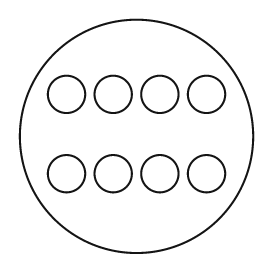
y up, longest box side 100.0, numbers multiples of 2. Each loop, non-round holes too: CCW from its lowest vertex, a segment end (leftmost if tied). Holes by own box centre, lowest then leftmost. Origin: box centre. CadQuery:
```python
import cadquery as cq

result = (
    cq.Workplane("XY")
    .moveTo(0.0, 0.0)
    .circle(50.0)
    .moveTo(-30.0, -16.0)
    .circle(8.0)
    .moveTo(-10.0, -16.0)
    .circle(8.0)
    .moveTo(10.0, -16.0)
    .circle(8.0)
    .moveTo(30.0, -16.0)
    .circle(8.0)
    .moveTo(-30.0, 18.0)
    .circle(8.0)
    .moveTo(-10.0, 18.0)
    .circle(8.0)
    .moveTo(10.0, 18.0)
    .circle(8.0)
    .moveTo(30.0, 18.0)
    .circle(8.0)
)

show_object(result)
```